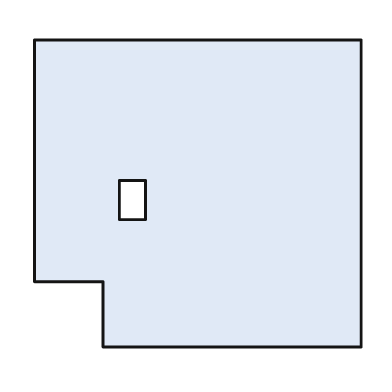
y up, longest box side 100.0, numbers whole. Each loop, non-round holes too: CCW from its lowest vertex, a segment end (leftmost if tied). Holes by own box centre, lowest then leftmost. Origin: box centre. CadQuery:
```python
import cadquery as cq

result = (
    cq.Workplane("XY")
    .moveTo(-29.0, -47.0)
    .lineTo(50.0, -47.0)
    .lineTo(50.0, 47.0)
    .lineTo(-50.0, 47.0)
    .lineTo(-50.0, -27.0)
    .lineTo(-29.0, -27.0)
    .close()
    .moveTo(-24.0, -8.0)
    .lineTo(-16.0, -8.0)
    .lineTo(-16.0, 4.0)
    .lineTo(-24.0, 4.0)
    .close()
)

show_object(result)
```